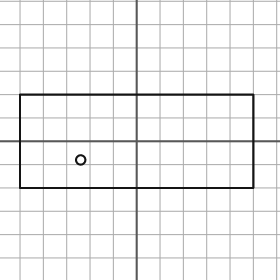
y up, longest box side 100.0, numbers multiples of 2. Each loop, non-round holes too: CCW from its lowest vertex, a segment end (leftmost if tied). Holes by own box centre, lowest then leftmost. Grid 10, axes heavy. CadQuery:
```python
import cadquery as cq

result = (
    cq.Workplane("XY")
    .moveTo(-50.0, -20.0)
    .lineTo(50.0, -20.0)
    .lineTo(50.0, 20.0)
    .lineTo(-50.0, 20.0)
    .close()
    .moveTo(-24.0, -8.0)
    .circle(2.0)
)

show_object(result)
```